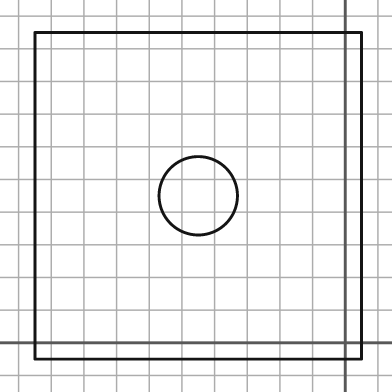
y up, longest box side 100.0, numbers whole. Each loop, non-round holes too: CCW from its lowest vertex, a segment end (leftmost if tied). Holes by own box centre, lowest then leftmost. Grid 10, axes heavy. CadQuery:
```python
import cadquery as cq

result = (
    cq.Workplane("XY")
    .moveTo(-95.0, -5.0)
    .lineTo(5.0, -5.0)
    .lineTo(5.0, 95.0)
    .lineTo(-95.0, 95.0)
    .close()
    .moveTo(-45.0, 45.0)
    .circle(12.0)
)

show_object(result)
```